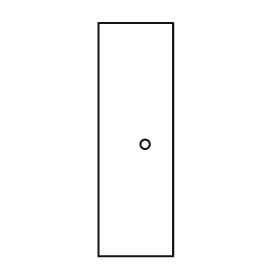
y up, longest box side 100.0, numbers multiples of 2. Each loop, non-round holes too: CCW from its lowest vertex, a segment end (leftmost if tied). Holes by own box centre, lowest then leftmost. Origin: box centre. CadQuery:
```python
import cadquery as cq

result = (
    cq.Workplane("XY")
    .moveTo(-16.0, -50.0)
    .lineTo(16.0, -50.0)
    .lineTo(16.0, 50.0)
    .lineTo(-16.0, 50.0)
    .close()
    .moveTo(4.0, -2.0)
    .circle(2.0)
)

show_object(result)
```